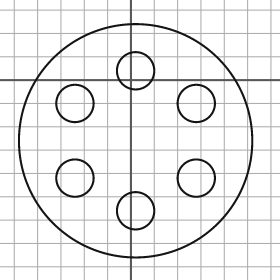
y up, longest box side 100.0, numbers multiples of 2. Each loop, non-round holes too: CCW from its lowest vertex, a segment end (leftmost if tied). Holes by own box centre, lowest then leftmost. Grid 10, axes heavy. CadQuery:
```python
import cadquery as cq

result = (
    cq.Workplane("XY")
    .moveTo(2.0, -26.0)
    .circle(50.0)
    .moveTo(2.0, -56.0)
    .circle(8.0)
    .moveTo(-24.0, -42.0)
    .circle(8.0)
    .moveTo(28.0, -42.0)
    .circle(8.0)
    .moveTo(-24.0, -10.0)
    .circle(8.0)
    .moveTo(28.0, -10.0)
    .circle(8.0)
    .moveTo(2.0, 4.0)
    .circle(8.0)
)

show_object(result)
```